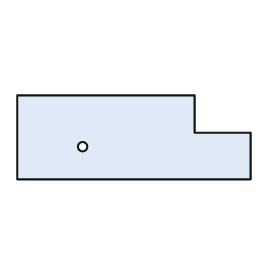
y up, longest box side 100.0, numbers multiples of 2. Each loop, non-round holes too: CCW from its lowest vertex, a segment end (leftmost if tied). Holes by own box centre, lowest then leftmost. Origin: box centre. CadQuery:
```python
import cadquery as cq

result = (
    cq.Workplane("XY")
    .moveTo(-50.0, -18.0)
    .lineTo(50.0, -18.0)
    .lineTo(50.0, 2.0)
    .lineTo(26.0, 2.0)
    .lineTo(26.0, 18.0)
    .lineTo(-50.0, 18.0)
    .close()
    .moveTo(-22.0, -4.0)
    .circle(2.0)
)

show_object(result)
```